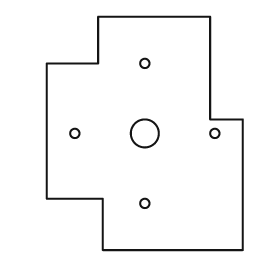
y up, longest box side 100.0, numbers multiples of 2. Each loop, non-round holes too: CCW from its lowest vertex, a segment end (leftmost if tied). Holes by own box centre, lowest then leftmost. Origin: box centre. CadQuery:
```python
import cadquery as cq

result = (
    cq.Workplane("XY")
    .moveTo(-18.0, -50.0)
    .lineTo(42.0, -50.0)
    .lineTo(42.0, 6.0)
    .lineTo(28.0, 6.0)
    .lineTo(28.0, 50.0)
    .lineTo(-20.0, 50.0)
    .lineTo(-20.0, 30.0)
    .lineTo(-42.0, 30.0)
    .lineTo(-42.0, -28.0)
    .lineTo(-18.0, -28.0)
    .close()
    .moveTo(0.0, -30.0)
    .circle(2.0)
    .moveTo(-30.0, 0.0)
    .circle(2.0)
    .moveTo(0.0, 0.0)
    .circle(6.0)
    .moveTo(30.0, 0.0)
    .circle(2.0)
    .moveTo(0.0, 30.0)
    .circle(2.0)
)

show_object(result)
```